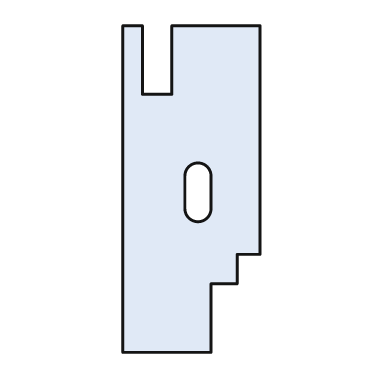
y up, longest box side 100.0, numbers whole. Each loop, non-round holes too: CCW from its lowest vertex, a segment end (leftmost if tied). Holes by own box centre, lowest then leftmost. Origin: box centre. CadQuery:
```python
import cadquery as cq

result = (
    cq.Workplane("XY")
    .moveTo(-21.0, -50.0)
    .lineTo(6.0, -50.0)
    .lineTo(6.0, -29.0)
    .lineTo(14.0, -29.0)
    .lineTo(14.0, -20.0)
    .lineTo(21.0, -20.0)
    .lineTo(21.0, 50.0)
    .lineTo(-6.0, 50.0)
    .lineTo(-6.0, 29.0)
    .lineTo(-15.0, 29.0)
    .lineTo(-15.0, 50.0)
    .lineTo(-21.0, 50.0)
    .close()
    .moveTo(-2.0, -6.0)
    .threePointArc((2.0, -10.0), (6.0, -6.0))
    .lineTo(6.0, 4.0)
    .threePointArc((2.0, 8.0), (-2.0, 4.0))
    .close()
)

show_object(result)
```